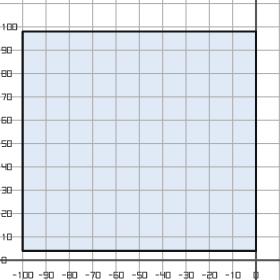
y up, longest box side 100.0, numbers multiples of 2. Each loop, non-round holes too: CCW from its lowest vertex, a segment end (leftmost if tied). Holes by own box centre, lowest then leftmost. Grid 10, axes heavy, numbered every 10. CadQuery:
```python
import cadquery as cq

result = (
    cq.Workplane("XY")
    .moveTo(-100.0, 4.0)
    .lineTo(0.0, 4.0)
    .lineTo(0.0, 98.0)
    .lineTo(-100.0, 98.0)
    .close()
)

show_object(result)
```